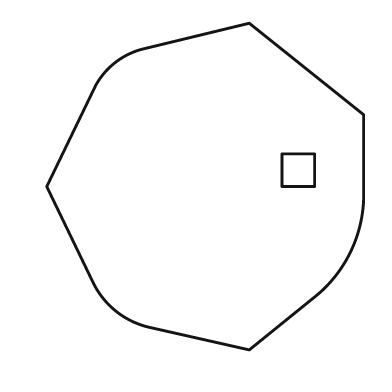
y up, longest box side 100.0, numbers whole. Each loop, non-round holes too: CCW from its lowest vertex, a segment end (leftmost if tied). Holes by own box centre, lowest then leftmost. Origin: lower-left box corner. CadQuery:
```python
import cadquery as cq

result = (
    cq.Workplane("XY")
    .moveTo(62.0, 0.0)
    .lineTo(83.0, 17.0)
    .threePointArc((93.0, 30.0), (97.0, 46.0))
    .lineTo(97.0, 72.0)
    .lineTo(62.0, 100.0)
    .lineTo(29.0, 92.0)
    .threePointArc((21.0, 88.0), (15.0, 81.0))
    .lineTo(0.0, 50.0)
    .lineTo(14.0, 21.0)
    .threePointArc((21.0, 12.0), (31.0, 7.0))
    .close()
    .moveTo(72.0, 50.0)
    .lineTo(82.0, 50.0)
    .lineTo(82.0, 60.0)
    .lineTo(72.0, 60.0)
    .close()
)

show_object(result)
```